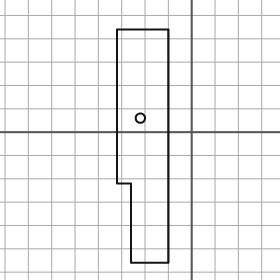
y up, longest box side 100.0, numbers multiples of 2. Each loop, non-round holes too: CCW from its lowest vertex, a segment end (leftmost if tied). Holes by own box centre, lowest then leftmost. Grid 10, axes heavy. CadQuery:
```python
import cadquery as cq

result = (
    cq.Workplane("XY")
    .moveTo(-26.0, -56.0)
    .lineTo(-10.0, -56.0)
    .lineTo(-10.0, 44.0)
    .lineTo(-32.0, 44.0)
    .lineTo(-32.0, -22.0)
    .lineTo(-26.0, -22.0)
    .close()
    .moveTo(-22.0, 6.0)
    .circle(2.0)
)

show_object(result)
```